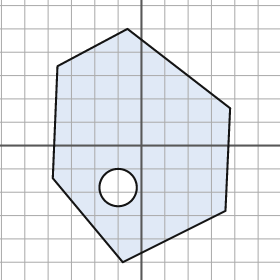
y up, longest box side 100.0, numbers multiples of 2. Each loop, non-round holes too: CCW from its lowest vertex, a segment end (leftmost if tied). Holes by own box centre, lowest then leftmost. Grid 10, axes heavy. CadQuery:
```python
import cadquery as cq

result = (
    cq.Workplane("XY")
    .moveTo(-8.0, -50.0)
    .lineTo(36.0, -28.0)
    .lineTo(38.0, 16.0)
    .lineTo(-6.0, 50.0)
    .lineTo(-36.0, 34.0)
    .lineTo(-38.0, -14.0)
    .close()
    .moveTo(-10.0, -18.0)
    .circle(8.0)
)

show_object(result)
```